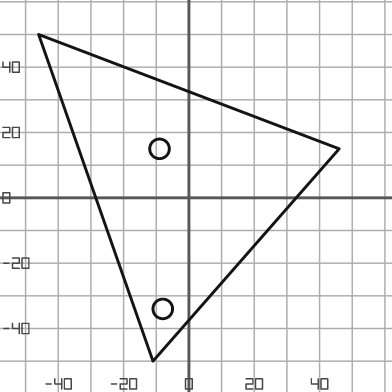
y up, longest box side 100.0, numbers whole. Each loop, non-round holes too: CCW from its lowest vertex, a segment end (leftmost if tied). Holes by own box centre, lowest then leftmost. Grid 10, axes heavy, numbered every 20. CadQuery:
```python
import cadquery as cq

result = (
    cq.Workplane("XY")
    .moveTo(-11.0, -50.0)
    .lineTo(46.0, 15.0)
    .lineTo(-46.0, 50.0)
    .close()
    .moveTo(-8.0, -34.0)
    .circle(3.0)
    .moveTo(-9.0, 15.0)
    .circle(3.0)
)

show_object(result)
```